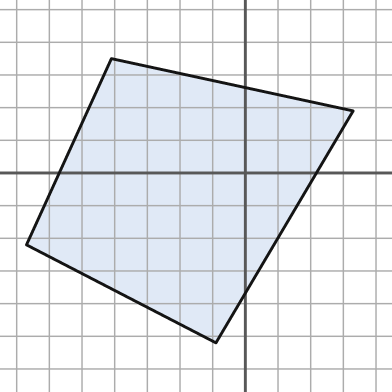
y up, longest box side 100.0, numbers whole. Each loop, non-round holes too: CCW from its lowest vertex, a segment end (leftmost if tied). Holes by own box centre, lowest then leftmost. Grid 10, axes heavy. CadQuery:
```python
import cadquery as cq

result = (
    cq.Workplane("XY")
    .moveTo(-9.0, -52.0)
    .lineTo(33.0, 19.0)
    .lineTo(-41.0, 35.0)
    .lineTo(-67.0, -22.0)
    .close()
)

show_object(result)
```